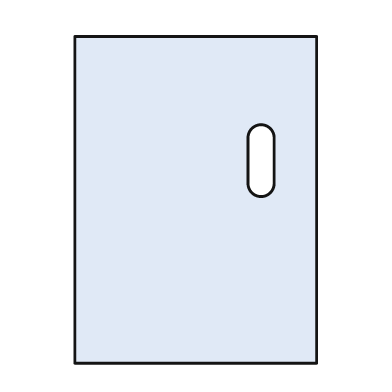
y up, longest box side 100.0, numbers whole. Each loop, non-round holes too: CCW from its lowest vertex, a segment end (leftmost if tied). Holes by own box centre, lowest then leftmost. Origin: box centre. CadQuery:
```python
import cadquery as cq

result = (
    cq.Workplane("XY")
    .moveTo(-37.0, -50.0)
    .lineTo(37.0, -50.0)
    .lineTo(37.0, 50.0)
    .lineTo(-37.0, 50.0)
    .close()
    .moveTo(16.0, 5.0)
    .threePointArc((20.0, 1.0), (24.0, 5.0))
    .lineTo(24.0, 19.0)
    .threePointArc((20.0, 23.0), (16.0, 19.0))
    .close()
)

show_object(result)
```